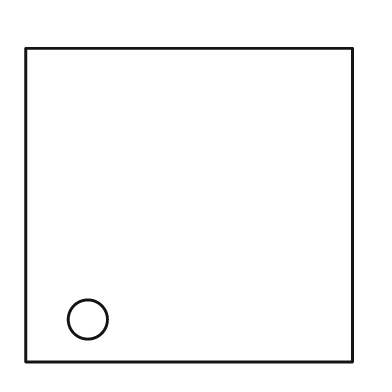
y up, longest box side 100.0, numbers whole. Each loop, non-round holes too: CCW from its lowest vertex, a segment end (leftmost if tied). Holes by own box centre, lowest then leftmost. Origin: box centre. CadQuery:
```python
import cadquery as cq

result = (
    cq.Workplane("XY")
    .moveTo(-50.0, -48.0)
    .lineTo(50.0, -48.0)
    .lineTo(50.0, 48.0)
    .lineTo(-50.0, 48.0)
    .close()
    .moveTo(-31.0, -35.0)
    .circle(6.0)
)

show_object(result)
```